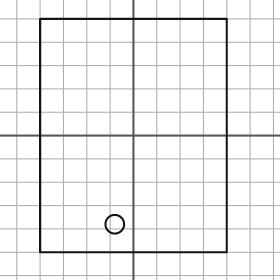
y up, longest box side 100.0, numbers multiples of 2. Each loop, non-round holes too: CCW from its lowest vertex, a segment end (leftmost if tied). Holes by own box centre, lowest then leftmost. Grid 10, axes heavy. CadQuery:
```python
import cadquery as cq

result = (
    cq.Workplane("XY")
    .moveTo(-40.0, -50.0)
    .lineTo(40.0, -50.0)
    .lineTo(40.0, 50.0)
    .lineTo(-40.0, 50.0)
    .close()
    .moveTo(-8.0, -38.0)
    .circle(4.0)
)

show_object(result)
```